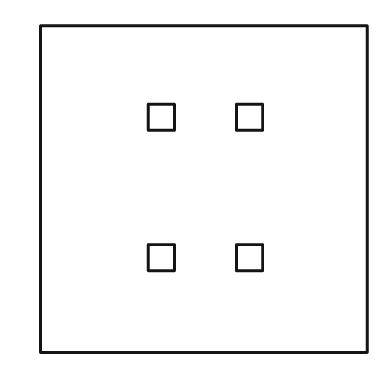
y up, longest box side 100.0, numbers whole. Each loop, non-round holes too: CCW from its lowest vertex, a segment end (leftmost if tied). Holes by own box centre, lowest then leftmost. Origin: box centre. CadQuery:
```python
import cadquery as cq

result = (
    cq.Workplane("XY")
    .moveTo(-50.0, -50.0)
    .lineTo(50.0, -50.0)
    .lineTo(50.0, 50.0)
    .lineTo(-50.0, 50.0)
    .close()
    .moveTo(-17.0, -25.0)
    .lineTo(-9.0, -25.0)
    .lineTo(-9.0, -17.0)
    .lineTo(-17.0, -17.0)
    .close()
    .moveTo(10.0, -25.0)
    .lineTo(18.0, -25.0)
    .lineTo(18.0, -17.0)
    .lineTo(10.0, -17.0)
    .close()
    .moveTo(-17.0, 18.0)
    .lineTo(-9.0, 18.0)
    .lineTo(-9.0, 26.0)
    .lineTo(-17.0, 26.0)
    .close()
    .moveTo(10.0, 18.0)
    .lineTo(18.0, 18.0)
    .lineTo(18.0, 26.0)
    .lineTo(10.0, 26.0)
    .close()
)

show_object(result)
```